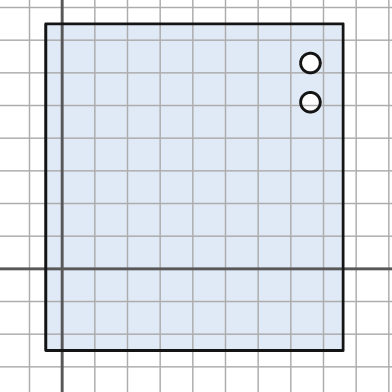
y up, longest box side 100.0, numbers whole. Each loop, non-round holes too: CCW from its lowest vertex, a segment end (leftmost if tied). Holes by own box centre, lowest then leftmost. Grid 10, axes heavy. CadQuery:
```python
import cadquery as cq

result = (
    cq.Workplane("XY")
    .moveTo(-5.0, -25.0)
    .lineTo(86.0, -25.0)
    .lineTo(86.0, 75.0)
    .lineTo(-5.0, 75.0)
    .close()
    .moveTo(76.0, 51.0)
    .circle(3.0)
    .moveTo(76.0, 63.0)
    .circle(3.0)
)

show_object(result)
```